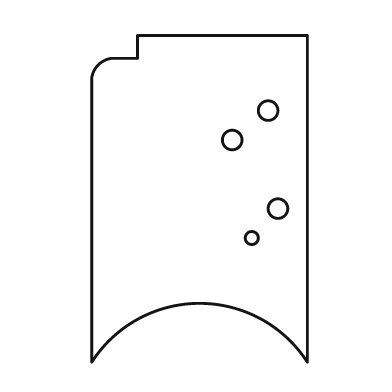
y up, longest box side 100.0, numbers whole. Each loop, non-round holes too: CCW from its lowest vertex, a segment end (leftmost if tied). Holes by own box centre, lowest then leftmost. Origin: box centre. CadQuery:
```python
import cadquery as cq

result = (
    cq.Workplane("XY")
    .moveTo(-33.0, -50.0)
    .threePointArc((0.0, -32.0), (33.0, -50.0))
    .lineTo(33.0, 50.0)
    .lineTo(-19.0, 50.0)
    .lineTo(-19.0, 43.0)
    .lineTo(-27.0, 43.0)
    .threePointArc((-31.0, 41.0), (-33.0, 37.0))
    .close()
    .moveTo(16.0, -12.0)
    .circle(2.0)
    .moveTo(24.0, -3.0)
    .circle(3.0)
    .moveTo(10.0, 18.0)
    .circle(3.0)
    .moveTo(21.0, 27.0)
    .circle(3.0)
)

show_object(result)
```